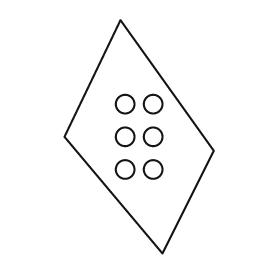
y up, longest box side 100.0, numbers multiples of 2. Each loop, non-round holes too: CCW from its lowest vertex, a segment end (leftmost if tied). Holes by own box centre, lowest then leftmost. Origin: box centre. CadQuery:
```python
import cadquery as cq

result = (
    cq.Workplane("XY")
    .moveTo(10.0, -50.0)
    .lineTo(32.0, -6.0)
    .lineTo(-8.0, 50.0)
    .lineTo(-32.0, 0.0)
    .close()
    .moveTo(-6.0, -14.0)
    .circle(4.0)
    .moveTo(6.0, -14.0)
    .circle(4.0)
    .moveTo(-6.0, 0.0)
    .circle(4.0)
    .moveTo(6.0, 0.0)
    .circle(4.0)
    .moveTo(-6.0, 14.0)
    .circle(4.0)
    .moveTo(6.0, 14.0)
    .circle(4.0)
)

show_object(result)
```